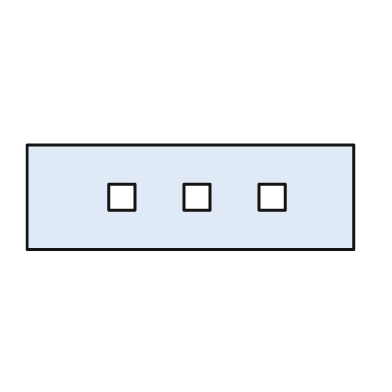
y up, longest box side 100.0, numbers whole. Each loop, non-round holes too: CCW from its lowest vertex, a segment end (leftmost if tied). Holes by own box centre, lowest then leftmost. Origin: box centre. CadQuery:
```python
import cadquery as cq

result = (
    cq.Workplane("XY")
    .moveTo(-50.0, -16.0)
    .lineTo(50.0, -16.0)
    .lineTo(50.0, 16.0)
    .lineTo(-50.0, 16.0)
    .close()
    .moveTo(-25.0, -4.0)
    .lineTo(-17.0, -4.0)
    .lineTo(-17.0, 4.0)
    .lineTo(-25.0, 4.0)
    .close()
    .moveTo(-2.0, -4.0)
    .lineTo(6.0, -4.0)
    .lineTo(6.0, 4.0)
    .lineTo(-2.0, 4.0)
    .close()
    .moveTo(21.0, -4.0)
    .lineTo(29.0, -4.0)
    .lineTo(29.0, 4.0)
    .lineTo(21.0, 4.0)
    .close()
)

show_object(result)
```